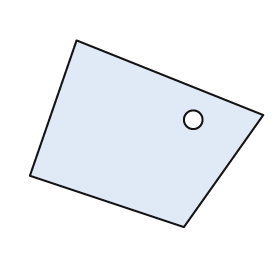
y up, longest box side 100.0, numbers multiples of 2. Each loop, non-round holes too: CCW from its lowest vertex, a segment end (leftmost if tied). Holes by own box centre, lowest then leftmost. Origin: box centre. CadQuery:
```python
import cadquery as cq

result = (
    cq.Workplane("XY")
    .moveTo(16.0, -40.0)
    .lineTo(50.0, 8.0)
    .lineTo(-30.0, 40.0)
    .lineTo(-50.0, -18.0)
    .close()
    .moveTo(20.0, 6.0)
    .circle(4.0)
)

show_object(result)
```